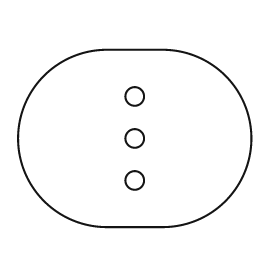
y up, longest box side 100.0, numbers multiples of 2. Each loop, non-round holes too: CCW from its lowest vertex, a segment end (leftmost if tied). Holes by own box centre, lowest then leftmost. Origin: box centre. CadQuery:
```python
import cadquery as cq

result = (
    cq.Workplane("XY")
    .moveTo(-12.0, -38.0)
    .lineTo(12.0, -38.0)
    .threePointArc((50.0, 0.0), (12.0, 38.0))
    .lineTo(-12.0, 38.0)
    .threePointArc((-50.0, 0.0), (-12.0, -38.0))
    .close()
    .moveTo(0.0, -18.0)
    .circle(4.0)
    .moveTo(0.0, 0.0)
    .circle(4.0)
    .moveTo(0.0, 18.0)
    .circle(4.0)
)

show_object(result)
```